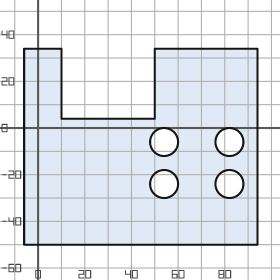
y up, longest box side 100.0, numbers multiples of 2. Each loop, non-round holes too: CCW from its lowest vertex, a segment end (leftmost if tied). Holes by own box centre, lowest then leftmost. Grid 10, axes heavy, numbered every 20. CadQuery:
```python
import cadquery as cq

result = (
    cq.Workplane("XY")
    .moveTo(-6.0, -50.0)
    .lineTo(94.0, -50.0)
    .lineTo(94.0, 34.0)
    .lineTo(50.0, 34.0)
    .lineTo(50.0, 4.0)
    .lineTo(10.0, 4.0)
    .lineTo(10.0, 34.0)
    .lineTo(-6.0, 34.0)
    .close()
    .moveTo(54.0, -24.0)
    .circle(6.0)
    .moveTo(82.0, -24.0)
    .circle(6.0)
    .moveTo(54.0, -6.0)
    .circle(6.0)
    .moveTo(82.0, -6.0)
    .circle(6.0)
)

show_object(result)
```